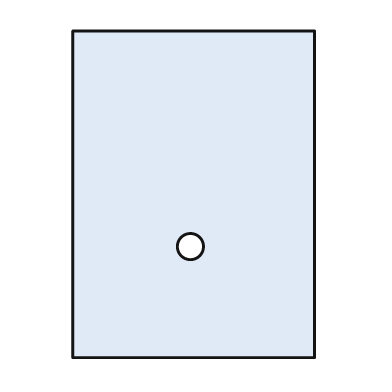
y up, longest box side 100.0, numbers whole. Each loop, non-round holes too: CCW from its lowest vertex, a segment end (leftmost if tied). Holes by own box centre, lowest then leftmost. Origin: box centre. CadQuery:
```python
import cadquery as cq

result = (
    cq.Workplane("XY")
    .moveTo(-37.0, -50.0)
    .lineTo(37.0, -50.0)
    .lineTo(37.0, 50.0)
    .lineTo(-37.0, 50.0)
    .close()
    .moveTo(-1.0, -16.0)
    .circle(4.0)
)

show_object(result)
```